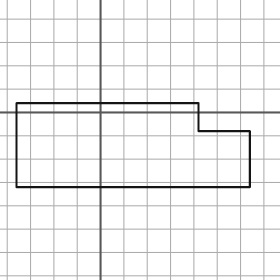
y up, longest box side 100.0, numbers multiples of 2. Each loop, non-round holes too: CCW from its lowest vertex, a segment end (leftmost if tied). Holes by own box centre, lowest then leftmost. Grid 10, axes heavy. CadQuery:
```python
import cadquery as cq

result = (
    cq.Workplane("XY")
    .moveTo(-36.0, -32.0)
    .lineTo(64.0, -32.0)
    .lineTo(64.0, -8.0)
    .lineTo(42.0, -8.0)
    .lineTo(42.0, 4.0)
    .lineTo(-36.0, 4.0)
    .close()
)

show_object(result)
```